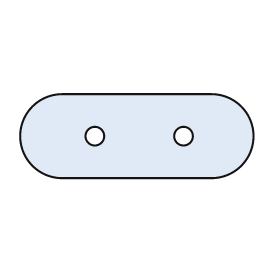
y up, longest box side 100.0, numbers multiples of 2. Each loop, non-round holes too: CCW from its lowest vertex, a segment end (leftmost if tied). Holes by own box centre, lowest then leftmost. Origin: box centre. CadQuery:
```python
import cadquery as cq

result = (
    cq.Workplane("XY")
    .moveTo(-32.0, -18.0)
    .lineTo(32.0, -18.0)
    .threePointArc((50.0, 0.0), (32.0, 18.0))
    .lineTo(-32.0, 18.0)
    .threePointArc((-50.0, 0.0), (-32.0, -18.0))
    .close()
    .moveTo(-18.0, 0.0)
    .circle(4.0)
    .moveTo(20.0, 0.0)
    .circle(4.0)
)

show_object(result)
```